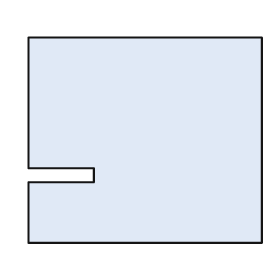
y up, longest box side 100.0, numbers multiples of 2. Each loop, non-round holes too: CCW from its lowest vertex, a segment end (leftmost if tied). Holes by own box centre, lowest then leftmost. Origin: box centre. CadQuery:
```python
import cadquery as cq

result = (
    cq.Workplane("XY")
    .moveTo(-50.0, -44.0)
    .lineTo(50.0, -44.0)
    .lineTo(50.0, 44.0)
    .lineTo(-50.0, 44.0)
    .lineTo(-50.0, -12.0)
    .lineTo(-22.0, -12.0)
    .lineTo(-22.0, -18.0)
    .lineTo(-50.0, -18.0)
    .close()
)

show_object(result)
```